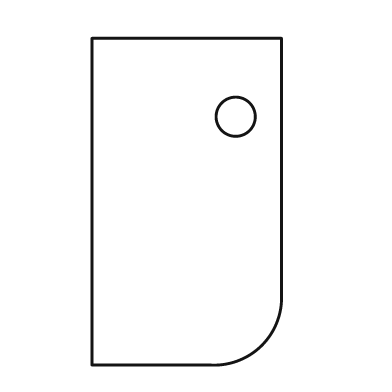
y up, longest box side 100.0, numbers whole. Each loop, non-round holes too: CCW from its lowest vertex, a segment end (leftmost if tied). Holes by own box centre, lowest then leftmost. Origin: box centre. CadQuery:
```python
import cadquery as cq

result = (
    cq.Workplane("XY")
    .moveTo(-29.0, -50.0)
    .lineTo(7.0, -50.0)
    .threePointArc((23.0, -44.0), (29.0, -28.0))
    .lineTo(29.0, 50.0)
    .lineTo(-29.0, 50.0)
    .close()
    .moveTo(15.0, 26.0)
    .circle(6.0)
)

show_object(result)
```